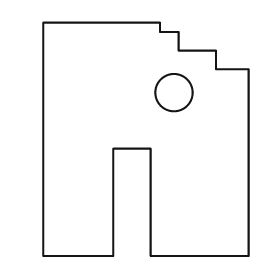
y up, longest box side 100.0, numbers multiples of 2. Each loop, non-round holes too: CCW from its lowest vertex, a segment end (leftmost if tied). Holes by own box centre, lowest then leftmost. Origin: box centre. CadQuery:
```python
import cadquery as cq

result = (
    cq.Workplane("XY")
    .moveTo(-44.0, -50.0)
    .lineTo(-14.0, -50.0)
    .lineTo(-14.0, -4.0)
    .lineTo(2.0, -4.0)
    .lineTo(2.0, -50.0)
    .lineTo(44.0, -50.0)
    .lineTo(44.0, 30.0)
    .lineTo(30.0, 30.0)
    .lineTo(30.0, 38.0)
    .lineTo(14.0, 38.0)
    .lineTo(14.0, 46.0)
    .lineTo(6.0, 46.0)
    .lineTo(6.0, 50.0)
    .lineTo(-44.0, 50.0)
    .close()
    .moveTo(12.0, 20.0)
    .circle(8.0)
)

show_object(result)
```